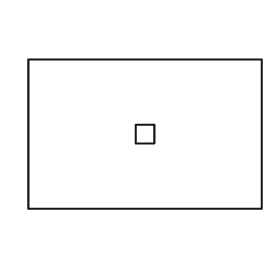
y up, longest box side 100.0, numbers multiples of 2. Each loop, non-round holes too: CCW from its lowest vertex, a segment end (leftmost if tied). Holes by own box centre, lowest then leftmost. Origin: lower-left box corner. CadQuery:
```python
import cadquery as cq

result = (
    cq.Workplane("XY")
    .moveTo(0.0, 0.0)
    .lineTo(100.0, 0.0)
    .lineTo(100.0, 64.0)
    .lineTo(0.0, 64.0)
    .close()
    .moveTo(46.0, 28.0)
    .lineTo(54.0, 28.0)
    .lineTo(54.0, 36.0)
    .lineTo(46.0, 36.0)
    .close()
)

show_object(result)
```